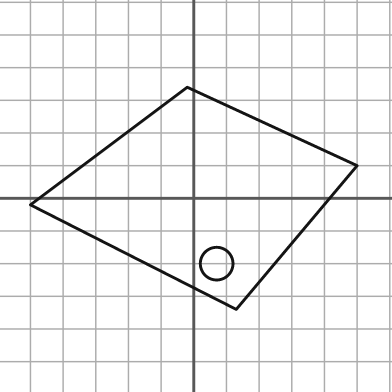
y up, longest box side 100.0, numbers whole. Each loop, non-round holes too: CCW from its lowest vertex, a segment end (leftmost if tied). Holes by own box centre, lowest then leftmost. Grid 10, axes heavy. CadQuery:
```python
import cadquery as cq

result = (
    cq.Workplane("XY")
    .moveTo(13.0, -34.0)
    .lineTo(50.0, 10.0)
    .lineTo(-2.0, 34.0)
    .lineTo(-50.0, -2.0)
    .close()
    .moveTo(7.0, -20.0)
    .circle(5.0)
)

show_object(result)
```